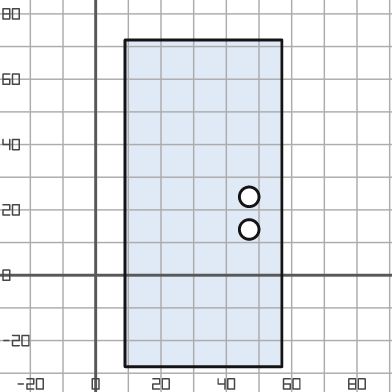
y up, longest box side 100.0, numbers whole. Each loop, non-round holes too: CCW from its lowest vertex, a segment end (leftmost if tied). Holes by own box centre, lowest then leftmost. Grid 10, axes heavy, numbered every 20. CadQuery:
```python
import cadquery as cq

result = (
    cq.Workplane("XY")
    .moveTo(9.0, -28.0)
    .lineTo(57.0, -28.0)
    .lineTo(57.0, 72.0)
    .lineTo(9.0, 72.0)
    .close()
    .moveTo(47.0, 14.0)
    .circle(3.0)
    .moveTo(47.0, 24.0)
    .circle(3.0)
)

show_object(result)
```